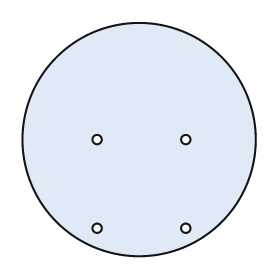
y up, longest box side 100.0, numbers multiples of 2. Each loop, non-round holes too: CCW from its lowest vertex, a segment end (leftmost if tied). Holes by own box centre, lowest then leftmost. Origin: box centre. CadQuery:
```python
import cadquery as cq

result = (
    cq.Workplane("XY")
    .moveTo(0.0, 0.0)
    .circle(50.0)
    .moveTo(-18.0, -38.0)
    .circle(2.0)
    .moveTo(20.0, -38.0)
    .circle(2.0)
    .moveTo(-18.0, 0.0)
    .circle(2.0)
    .moveTo(20.0, 0.0)
    .circle(2.0)
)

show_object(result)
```